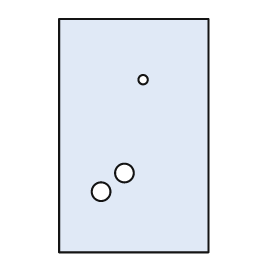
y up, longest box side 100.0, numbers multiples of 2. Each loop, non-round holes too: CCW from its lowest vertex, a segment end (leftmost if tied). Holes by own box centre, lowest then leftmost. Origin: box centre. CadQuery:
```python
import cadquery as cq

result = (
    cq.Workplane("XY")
    .moveTo(-32.0, -50.0)
    .lineTo(32.0, -50.0)
    .lineTo(32.0, 50.0)
    .lineTo(-32.0, 50.0)
    .close()
    .moveTo(-14.0, -24.0)
    .circle(4.0)
    .moveTo(-4.0, -16.0)
    .circle(4.0)
    .moveTo(4.0, 24.0)
    .circle(2.0)
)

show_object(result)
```